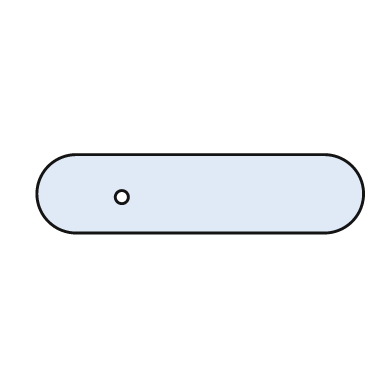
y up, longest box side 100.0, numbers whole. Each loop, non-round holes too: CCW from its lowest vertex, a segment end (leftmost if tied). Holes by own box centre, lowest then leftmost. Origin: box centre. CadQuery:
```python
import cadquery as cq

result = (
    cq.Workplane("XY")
    .moveTo(-38.0, -12.0)
    .lineTo(38.0, -12.0)
    .threePointArc((50.0, 0.0), (38.0, 12.0))
    .lineTo(-38.0, 12.0)
    .threePointArc((-50.0, 0.0), (-38.0, -12.0))
    .close()
    .moveTo(-24.0, -1.0)
    .circle(2.0)
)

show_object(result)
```